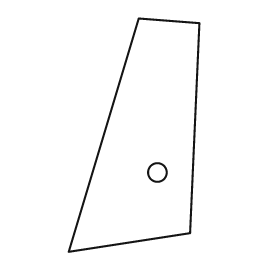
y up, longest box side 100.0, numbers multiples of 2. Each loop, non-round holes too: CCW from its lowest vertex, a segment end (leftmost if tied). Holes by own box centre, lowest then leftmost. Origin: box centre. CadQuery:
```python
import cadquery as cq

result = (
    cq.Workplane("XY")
    .moveTo(-28.0, -50.0)
    .lineTo(24.0, -42.0)
    .lineTo(28.0, 48.0)
    .lineTo(2.0, 50.0)
    .close()
    .moveTo(10.0, -16.0)
    .circle(4.0)
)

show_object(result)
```